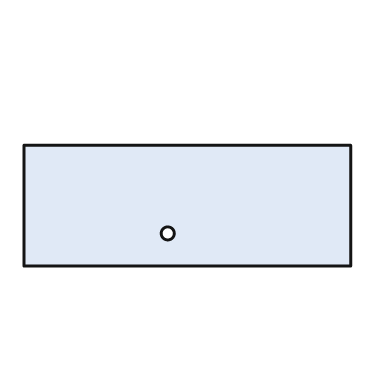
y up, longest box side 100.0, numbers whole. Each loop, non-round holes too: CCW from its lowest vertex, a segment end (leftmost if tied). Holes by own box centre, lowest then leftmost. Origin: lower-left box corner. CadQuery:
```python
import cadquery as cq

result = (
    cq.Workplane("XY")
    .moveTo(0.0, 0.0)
    .lineTo(100.0, 0.0)
    .lineTo(100.0, 37.0)
    .lineTo(0.0, 37.0)
    .close()
    .moveTo(44.0, 10.0)
    .circle(2.0)
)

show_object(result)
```